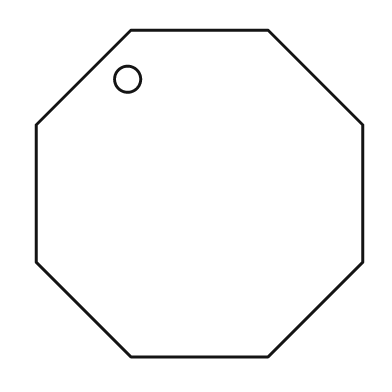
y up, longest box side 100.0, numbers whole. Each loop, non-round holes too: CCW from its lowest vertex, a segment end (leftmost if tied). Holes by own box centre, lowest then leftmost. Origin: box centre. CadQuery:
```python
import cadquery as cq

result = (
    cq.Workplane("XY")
    .moveTo(-21.0, -50.0)
    .lineTo(21.0, -50.0)
    .lineTo(50.0, -21.0)
    .lineTo(50.0, 21.0)
    .lineTo(21.0, 50.0)
    .lineTo(-21.0, 50.0)
    .lineTo(-50.0, 21.0)
    .lineTo(-50.0, -21.0)
    .close()
    .moveTo(-22.0, 35.0)
    .circle(4.0)
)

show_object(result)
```